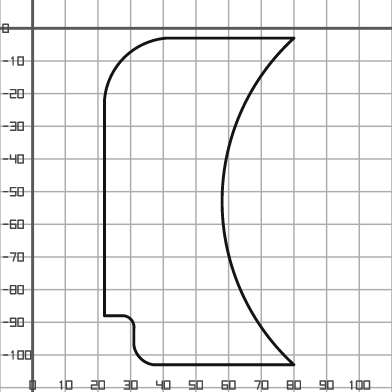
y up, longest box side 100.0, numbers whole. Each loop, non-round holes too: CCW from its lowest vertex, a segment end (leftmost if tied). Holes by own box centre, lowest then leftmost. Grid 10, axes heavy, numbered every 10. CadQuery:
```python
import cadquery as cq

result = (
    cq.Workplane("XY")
    .moveTo(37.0, -103.0)
    .lineTo(80.0, -103.0)
    .threePointArc((58.0, -53.0), (80.0, -3.0))
    .lineTo(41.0, -3.0)
    .threePointArc((28.0, -9.0), (22.0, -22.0))
    .lineTo(22.0, -88.0)
    .lineTo(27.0, -88.0)
    .threePointArc((30.0, -89.0), (31.0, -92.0))
    .lineTo(31.0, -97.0)
    .threePointArc((33.0, -101.0), (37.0, -103.0))
    .close()
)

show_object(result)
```